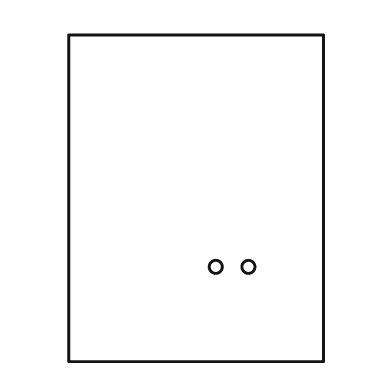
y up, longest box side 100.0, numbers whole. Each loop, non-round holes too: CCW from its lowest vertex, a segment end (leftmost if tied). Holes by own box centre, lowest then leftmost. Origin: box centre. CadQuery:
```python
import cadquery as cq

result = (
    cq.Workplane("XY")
    .moveTo(-39.0, -50.0)
    .lineTo(39.0, -50.0)
    .lineTo(39.0, 50.0)
    .lineTo(-39.0, 50.0)
    .close()
    .moveTo(6.0, -21.0)
    .circle(2.0)
    .moveTo(16.0, -21.0)
    .circle(2.0)
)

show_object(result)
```